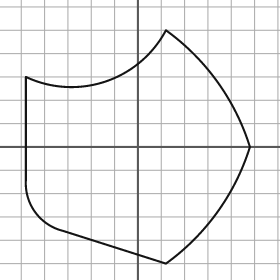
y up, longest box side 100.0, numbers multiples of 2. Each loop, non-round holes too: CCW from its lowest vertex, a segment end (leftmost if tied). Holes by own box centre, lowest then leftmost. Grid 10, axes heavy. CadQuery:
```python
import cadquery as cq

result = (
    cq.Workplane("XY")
    .moveTo(12.0, -50.0)
    .threePointArc((34.0, -28.0), (48.0, 0.0))
    .threePointArc((34.0, 28.0), (12.0, 50.0))
    .threePointArc((-14.0, 28.0), (-48.0, 30.0))
    .lineTo(-48.0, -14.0)
    .threePointArc((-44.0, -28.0), (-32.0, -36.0))
    .close()
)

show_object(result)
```